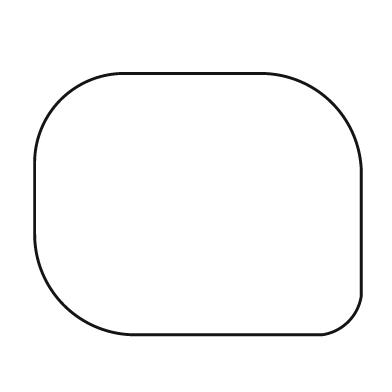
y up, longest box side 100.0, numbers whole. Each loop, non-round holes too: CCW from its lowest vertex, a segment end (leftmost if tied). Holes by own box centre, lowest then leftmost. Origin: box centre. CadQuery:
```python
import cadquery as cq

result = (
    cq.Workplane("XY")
    .moveTo(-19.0, -40.0)
    .lineTo(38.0, -40.0)
    .threePointArc((46.0, -36.0), (50.0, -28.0))
    .lineTo(50.0, 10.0)
    .threePointArc((41.0, 31.0), (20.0, 40.0))
    .lineTo(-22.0, 40.0)
    .threePointArc((-42.0, 32.0), (-50.0, 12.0))
    .lineTo(-50.0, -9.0)
    .threePointArc((-41.0, -31.0), (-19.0, -40.0))
    .close()
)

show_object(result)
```